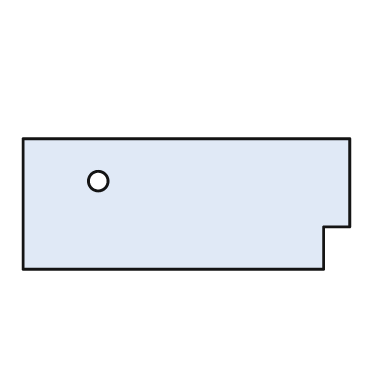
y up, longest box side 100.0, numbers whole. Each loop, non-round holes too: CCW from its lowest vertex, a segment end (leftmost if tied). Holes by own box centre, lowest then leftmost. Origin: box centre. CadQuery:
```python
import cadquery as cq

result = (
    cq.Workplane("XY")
    .moveTo(-50.0, -20.0)
    .lineTo(42.0, -20.0)
    .lineTo(42.0, -7.0)
    .lineTo(50.0, -7.0)
    .lineTo(50.0, 20.0)
    .lineTo(-50.0, 20.0)
    .close()
    .moveTo(-27.0, 7.0)
    .circle(3.0)
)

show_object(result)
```